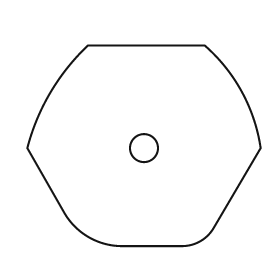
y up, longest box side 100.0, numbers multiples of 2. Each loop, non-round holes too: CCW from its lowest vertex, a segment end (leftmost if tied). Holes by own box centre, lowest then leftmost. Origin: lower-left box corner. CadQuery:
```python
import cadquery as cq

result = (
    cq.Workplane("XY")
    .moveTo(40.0, 0.0)
    .lineTo(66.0, 0.0)
    .threePointArc((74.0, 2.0), (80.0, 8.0))
    .lineTo(100.0, 42.0)
    .threePointArc((92.0, 66.0), (76.0, 86.0))
    .lineTo(26.0, 86.0)
    .threePointArc((10.0, 66.0), (0.0, 42.0))
    .lineTo(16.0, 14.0)
    .threePointArc((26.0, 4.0), (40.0, 0.0))
    .close()
    .moveTo(50.0, 42.0)
    .circle(6.0)
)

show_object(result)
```